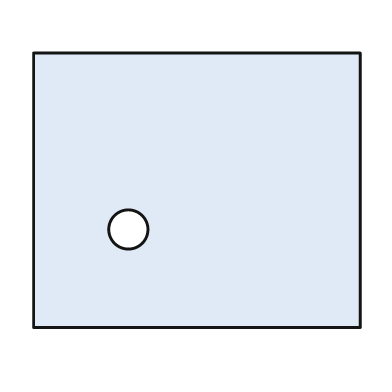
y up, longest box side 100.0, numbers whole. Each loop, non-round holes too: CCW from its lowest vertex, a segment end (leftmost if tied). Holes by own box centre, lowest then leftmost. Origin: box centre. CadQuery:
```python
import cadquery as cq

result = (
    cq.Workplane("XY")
    .moveTo(-50.0, -42.0)
    .lineTo(50.0, -42.0)
    .lineTo(50.0, 42.0)
    .lineTo(-50.0, 42.0)
    .close()
    .moveTo(-21.0, -12.0)
    .circle(6.0)
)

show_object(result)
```